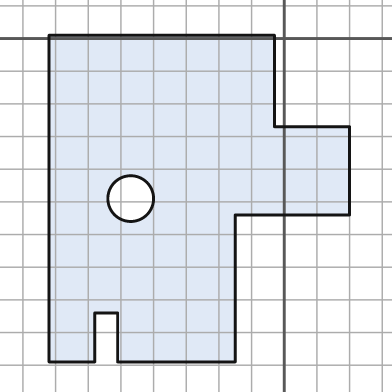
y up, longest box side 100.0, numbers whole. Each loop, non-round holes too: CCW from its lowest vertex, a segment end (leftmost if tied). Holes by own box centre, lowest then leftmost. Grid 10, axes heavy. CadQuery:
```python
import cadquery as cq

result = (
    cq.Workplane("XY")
    .moveTo(-72.0, -99.0)
    .lineTo(-58.0, -99.0)
    .lineTo(-58.0, -84.0)
    .lineTo(-51.0, -84.0)
    .lineTo(-51.0, -99.0)
    .lineTo(-15.0, -99.0)
    .lineTo(-15.0, -54.0)
    .lineTo(20.0, -54.0)
    .lineTo(20.0, -27.0)
    .lineTo(-3.0, -27.0)
    .lineTo(-3.0, 1.0)
    .lineTo(-72.0, 1.0)
    .close()
    .moveTo(-47.0, -49.0)
    .circle(7.0)
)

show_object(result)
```